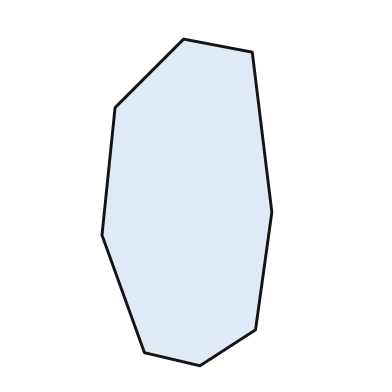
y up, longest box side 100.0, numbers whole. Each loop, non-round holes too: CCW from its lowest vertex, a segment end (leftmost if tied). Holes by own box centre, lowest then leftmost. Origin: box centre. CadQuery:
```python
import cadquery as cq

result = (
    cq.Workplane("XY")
    .moveTo(4.0, -50.0)
    .lineTo(21.0, -39.0)
    .lineTo(26.0, -3.0)
    .lineTo(20.0, 46.0)
    .lineTo(-1.0, 50.0)
    .lineTo(-22.0, 29.0)
    .lineTo(-26.0, -10.0)
    .lineTo(-13.0, -46.0)
    .close()
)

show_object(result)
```